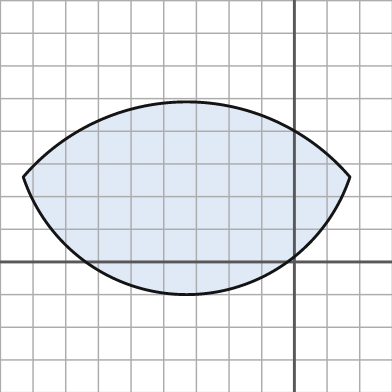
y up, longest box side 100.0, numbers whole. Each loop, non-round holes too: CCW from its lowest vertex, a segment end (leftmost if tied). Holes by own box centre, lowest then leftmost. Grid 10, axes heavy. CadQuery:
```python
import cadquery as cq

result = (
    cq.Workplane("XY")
    .moveTo(-83.0, 26.0)
    .threePointArc((-33.0, -10.0), (17.0, 26.0))
    .threePointArc((-33.0, 49.0), (-83.0, 26.0))
    .close()
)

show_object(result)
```